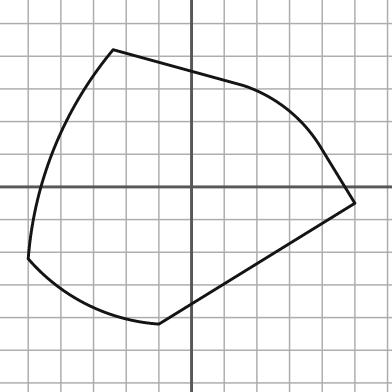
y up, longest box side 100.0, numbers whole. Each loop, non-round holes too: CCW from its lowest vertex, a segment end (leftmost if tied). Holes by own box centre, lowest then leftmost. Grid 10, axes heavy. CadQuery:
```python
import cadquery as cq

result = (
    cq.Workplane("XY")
    .moveTo(-10.0, -42.0)
    .lineTo(50.0, -5.0)
    .lineTo(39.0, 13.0)
    .threePointArc((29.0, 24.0), (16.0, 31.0))
    .lineTo(-24.0, 42.0)
    .threePointArc((-42.0, 12.0), (-50.0, -22.0))
    .threePointArc((-32.0, -36.0), (-10.0, -42.0))
    .close()
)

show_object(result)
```